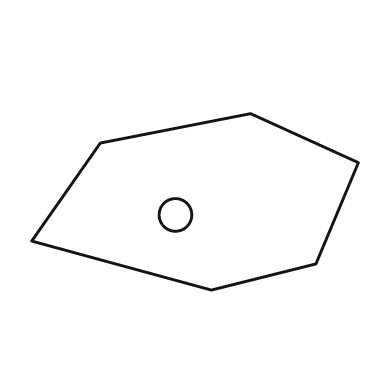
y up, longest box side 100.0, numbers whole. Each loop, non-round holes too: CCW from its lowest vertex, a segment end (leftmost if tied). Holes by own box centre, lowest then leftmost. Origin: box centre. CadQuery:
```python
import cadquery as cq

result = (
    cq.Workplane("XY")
    .moveTo(5.0, -27.0)
    .lineTo(37.0, -19.0)
    .lineTo(50.0, 12.0)
    .lineTo(17.0, 27.0)
    .lineTo(-29.0, 18.0)
    .lineTo(-50.0, -12.0)
    .close()
    .moveTo(-6.0, -4.0)
    .circle(5.0)
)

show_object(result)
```